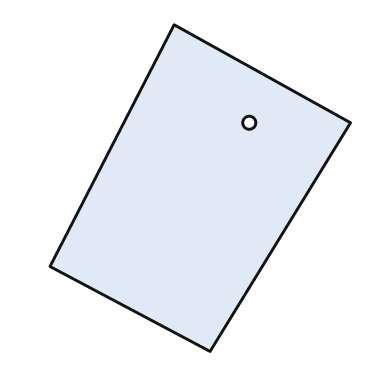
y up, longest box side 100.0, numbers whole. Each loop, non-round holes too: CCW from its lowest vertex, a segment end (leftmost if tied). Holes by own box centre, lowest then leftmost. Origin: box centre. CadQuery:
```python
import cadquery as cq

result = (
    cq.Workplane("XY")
    .moveTo(3.0, -50.0)
    .lineTo(46.0, 20.0)
    .lineTo(-8.0, 50.0)
    .lineTo(-46.0, -24.0)
    .close()
    .moveTo(15.0, 20.0)
    .circle(2.0)
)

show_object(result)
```